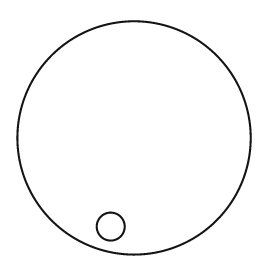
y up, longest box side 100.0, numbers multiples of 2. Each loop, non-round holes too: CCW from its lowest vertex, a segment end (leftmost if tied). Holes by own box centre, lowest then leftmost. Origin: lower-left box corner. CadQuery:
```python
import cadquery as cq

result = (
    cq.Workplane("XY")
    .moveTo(50.0, 50.0)
    .circle(50.0)
    .moveTo(40.0, 12.0)
    .circle(6.0)
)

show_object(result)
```